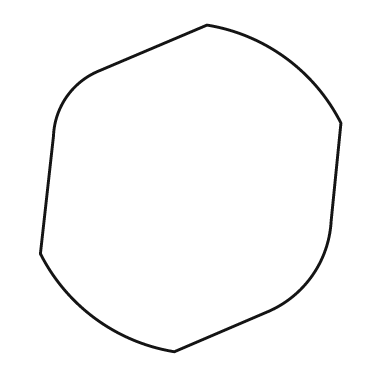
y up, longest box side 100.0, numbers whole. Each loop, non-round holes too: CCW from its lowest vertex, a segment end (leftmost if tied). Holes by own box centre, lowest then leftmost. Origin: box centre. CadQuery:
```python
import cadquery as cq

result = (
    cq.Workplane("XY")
    .moveTo(-5.0, -50.0)
    .lineTo(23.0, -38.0)
    .threePointArc((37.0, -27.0), (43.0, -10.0))
    .lineTo(46.0, 20.0)
    .threePointArc((29.0, 40.0), (5.0, 50.0))
    .lineTo(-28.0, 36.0)
    .threePointArc((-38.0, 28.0), (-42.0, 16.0))
    .lineTo(-46.0, -20.0)
    .threePointArc((-29.0, -40.0), (-5.0, -50.0))
    .close()
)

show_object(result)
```